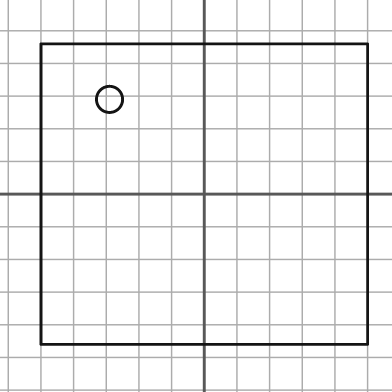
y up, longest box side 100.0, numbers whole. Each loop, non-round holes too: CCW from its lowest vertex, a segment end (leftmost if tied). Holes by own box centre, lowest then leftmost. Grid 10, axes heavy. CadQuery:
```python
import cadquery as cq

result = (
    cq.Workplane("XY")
    .moveTo(-50.0, -46.0)
    .lineTo(50.0, -46.0)
    .lineTo(50.0, 46.0)
    .lineTo(-50.0, 46.0)
    .close()
    .moveTo(-29.0, 29.0)
    .circle(4.0)
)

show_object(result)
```